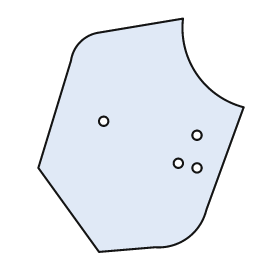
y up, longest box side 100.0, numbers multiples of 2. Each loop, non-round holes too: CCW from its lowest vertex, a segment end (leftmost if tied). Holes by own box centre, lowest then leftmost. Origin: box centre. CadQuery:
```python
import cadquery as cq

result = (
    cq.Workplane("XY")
    .moveTo(-18.0, -50.0)
    .lineTo(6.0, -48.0)
    .threePointArc((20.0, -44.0), (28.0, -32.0))
    .lineTo(44.0, 12.0)
    .threePointArc((24.0, 26.0), (18.0, 50.0))
    .lineTo(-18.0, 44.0)
    .threePointArc((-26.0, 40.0), (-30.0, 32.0))
    .lineTo(-44.0, -14.0)
    .close()
    .moveTo(24.0, -14.0)
    .circle(2.0)
    .moveTo(16.0, -12.0)
    .circle(2.0)
    .moveTo(24.0, 0.0)
    .circle(2.0)
    .moveTo(-16.0, 6.0)
    .circle(2.0)
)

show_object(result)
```